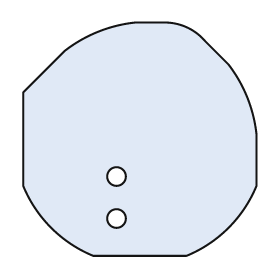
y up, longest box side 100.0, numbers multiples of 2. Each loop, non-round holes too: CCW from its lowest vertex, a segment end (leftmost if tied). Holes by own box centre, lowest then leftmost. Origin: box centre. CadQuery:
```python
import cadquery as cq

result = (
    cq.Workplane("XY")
    .moveTo(-20.0, -50.0)
    .lineTo(20.0, -50.0)
    .threePointArc((38.0, -38.0), (50.0, -20.0))
    .lineTo(50.0, 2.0)
    .threePointArc((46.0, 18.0), (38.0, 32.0))
    .lineTo(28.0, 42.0)
    .threePointArc((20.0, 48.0), (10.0, 50.0))
    .lineTo(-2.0, 50.0)
    .threePointArc((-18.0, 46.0), (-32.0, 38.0))
    .lineTo(-50.0, 20.0)
    .lineTo(-50.0, -20.0)
    .threePointArc((-38.0, -38.0), (-20.0, -50.0))
    .close()
    .moveTo(-10.0, -34.0)
    .circle(4.0)
    .moveTo(-10.0, -16.0)
    .circle(4.0)
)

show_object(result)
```